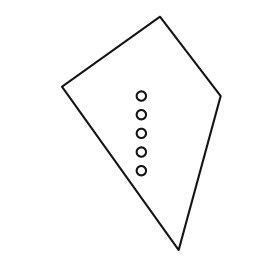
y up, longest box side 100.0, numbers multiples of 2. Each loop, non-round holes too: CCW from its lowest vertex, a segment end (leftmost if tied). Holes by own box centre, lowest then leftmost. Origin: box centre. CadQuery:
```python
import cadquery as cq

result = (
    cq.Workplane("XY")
    .moveTo(16.0, -50.0)
    .lineTo(34.0, 16.0)
    .lineTo(8.0, 50.0)
    .lineTo(-34.0, 20.0)
    .close()
    .moveTo(0.0, -16.0)
    .circle(2.0)
    .moveTo(0.0, -8.0)
    .circle(2.0)
    .moveTo(0.0, 0.0)
    .circle(2.0)
    .moveTo(0.0, 8.0)
    .circle(2.0)
    .moveTo(0.0, 16.0)
    .circle(2.0)
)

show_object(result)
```